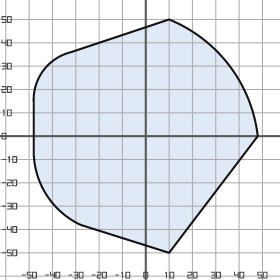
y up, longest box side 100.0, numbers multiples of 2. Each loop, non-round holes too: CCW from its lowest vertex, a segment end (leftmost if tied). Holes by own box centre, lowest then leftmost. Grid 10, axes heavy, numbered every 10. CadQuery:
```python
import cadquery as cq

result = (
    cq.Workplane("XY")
    .moveTo(10.0, -50.0)
    .lineTo(48.0, 0.0)
    .threePointArc((36.0, 30.0), (10.0, 50.0))
    .lineTo(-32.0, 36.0)
    .threePointArc((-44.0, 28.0), (-48.0, 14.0))
    .lineTo(-48.0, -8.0)
    .threePointArc((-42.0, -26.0), (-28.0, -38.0))
    .close()
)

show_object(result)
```